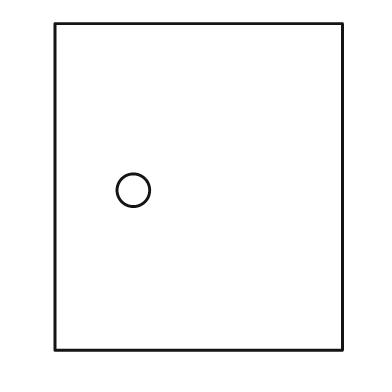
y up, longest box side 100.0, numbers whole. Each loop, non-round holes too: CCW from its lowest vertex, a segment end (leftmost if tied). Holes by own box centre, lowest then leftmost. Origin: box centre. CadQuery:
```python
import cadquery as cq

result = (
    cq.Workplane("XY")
    .moveTo(-44.0, -50.0)
    .lineTo(44.0, -50.0)
    .lineTo(44.0, 50.0)
    .lineTo(-44.0, 50.0)
    .close()
    .moveTo(-20.0, -1.0)
    .circle(5.0)
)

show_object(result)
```